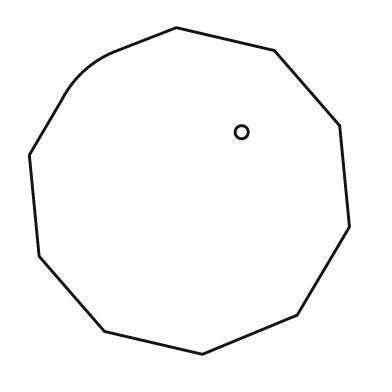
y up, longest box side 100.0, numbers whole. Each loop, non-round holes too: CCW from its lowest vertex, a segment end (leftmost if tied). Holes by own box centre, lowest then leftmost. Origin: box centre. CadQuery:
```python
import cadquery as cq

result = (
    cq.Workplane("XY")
    .moveTo(4.0, -50.0)
    .lineTo(33.0, -38.0)
    .lineTo(49.0, -11.0)
    .lineTo(46.0, 20.0)
    .lineTo(26.0, 43.0)
    .lineTo(-4.0, 50.0)
    .lineTo(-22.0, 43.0)
    .threePointArc((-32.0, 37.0), (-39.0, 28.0))
    .lineTo(-49.0, 11.0)
    .lineTo(-46.0, -20.0)
    .lineTo(-26.0, -43.0)
    .close()
    .moveTo(16.0, 18.0)
    .circle(2.0)
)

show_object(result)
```